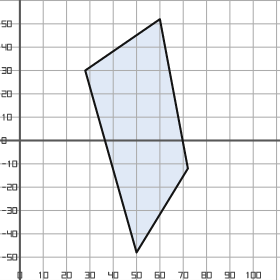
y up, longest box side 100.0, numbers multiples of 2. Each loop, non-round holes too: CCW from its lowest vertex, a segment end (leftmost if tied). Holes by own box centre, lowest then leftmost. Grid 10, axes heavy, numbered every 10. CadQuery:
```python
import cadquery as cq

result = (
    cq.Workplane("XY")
    .moveTo(50.0, -48.0)
    .lineTo(72.0, -12.0)
    .lineTo(60.0, 52.0)
    .lineTo(28.0, 30.0)
    .close()
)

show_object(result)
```